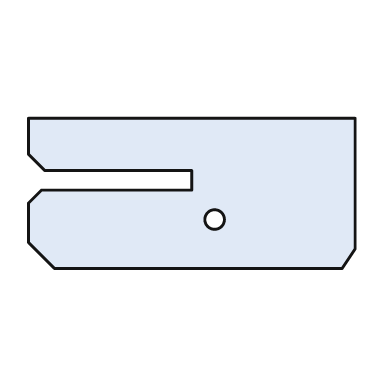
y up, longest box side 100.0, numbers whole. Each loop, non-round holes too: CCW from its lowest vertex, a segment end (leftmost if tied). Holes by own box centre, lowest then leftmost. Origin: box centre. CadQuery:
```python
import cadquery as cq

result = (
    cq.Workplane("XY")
    .moveTo(-42.0, -23.0)
    .lineTo(46.0, -23.0)
    .lineTo(50.0, -17.0)
    .lineTo(50.0, 23.0)
    .lineTo(-50.0, 23.0)
    .lineTo(-50.0, 12.0)
    .lineTo(-45.0, 7.0)
    .lineTo(0.0, 7.0)
    .lineTo(0.0, 1.0)
    .lineTo(-46.0, 1.0)
    .lineTo(-50.0, -3.0)
    .lineTo(-50.0, -15.0)
    .close()
    .moveTo(7.0, -8.0)
    .circle(3.0)
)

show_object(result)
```